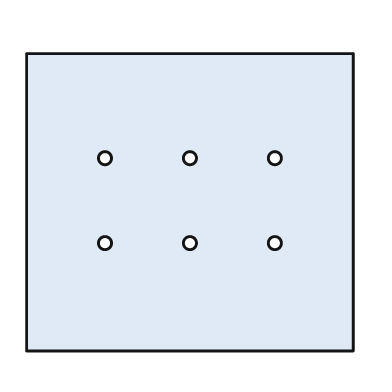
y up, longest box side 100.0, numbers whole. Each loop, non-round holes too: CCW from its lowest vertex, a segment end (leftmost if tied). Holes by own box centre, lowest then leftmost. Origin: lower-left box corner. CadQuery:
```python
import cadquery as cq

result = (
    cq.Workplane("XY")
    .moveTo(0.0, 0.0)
    .lineTo(100.0, 0.0)
    .lineTo(100.0, 91.0)
    .lineTo(0.0, 91.0)
    .close()
    .moveTo(24.0, 33.0)
    .circle(2.0)
    .moveTo(50.0, 33.0)
    .circle(2.0)
    .moveTo(76.0, 33.0)
    .circle(2.0)
    .moveTo(24.0, 59.0)
    .circle(2.0)
    .moveTo(50.0, 59.0)
    .circle(2.0)
    .moveTo(76.0, 59.0)
    .circle(2.0)
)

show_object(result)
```